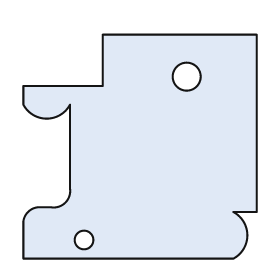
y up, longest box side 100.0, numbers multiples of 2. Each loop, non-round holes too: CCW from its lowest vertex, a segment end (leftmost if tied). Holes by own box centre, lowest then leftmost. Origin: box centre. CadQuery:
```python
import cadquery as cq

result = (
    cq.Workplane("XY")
    .moveTo(-50.0, -48.0)
    .lineTo(40.0, -48.0)
    .threePointArc((46.0, -38.0), (40.0, -28.0))
    .lineTo(50.0, -28.0)
    .lineTo(50.0, 48.0)
    .lineTo(-16.0, 48.0)
    .lineTo(-16.0, 26.0)
    .lineTo(-50.0, 26.0)
    .lineTo(-50.0, 18.0)
    .threePointArc((-40.0, 12.0), (-30.0, 18.0))
    .lineTo(-30.0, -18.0)
    .threePointArc((-32.0, -24.0), (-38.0, -26.0))
    .lineTo(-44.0, -26.0)
    .threePointArc((-48.0, -28.0), (-50.0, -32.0))
    .close()
    .moveTo(-24.0, -40.0)
    .circle(4.0)
    .moveTo(20.0, 30.0)
    .circle(6.0)
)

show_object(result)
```